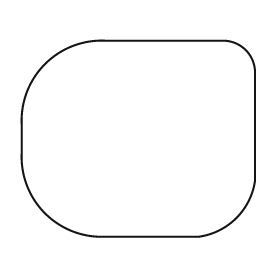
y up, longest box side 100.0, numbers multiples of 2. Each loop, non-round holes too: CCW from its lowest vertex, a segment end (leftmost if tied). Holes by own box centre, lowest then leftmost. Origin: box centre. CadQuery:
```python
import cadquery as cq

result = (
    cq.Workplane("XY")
    .moveTo(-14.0, -42.0)
    .lineTo(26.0, -42.0)
    .threePointArc((42.0, -34.0), (50.0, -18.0))
    .lineTo(50.0, 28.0)
    .threePointArc((46.0, 38.0), (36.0, 42.0))
    .lineTo(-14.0, 42.0)
    .threePointArc((-40.0, 32.0), (-50.0, 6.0))
    .lineTo(-50.0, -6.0)
    .threePointArc((-40.0, -32.0), (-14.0, -42.0))
    .close()
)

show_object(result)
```